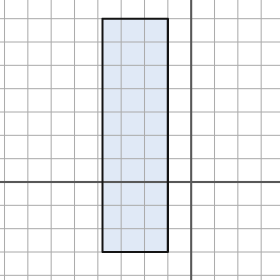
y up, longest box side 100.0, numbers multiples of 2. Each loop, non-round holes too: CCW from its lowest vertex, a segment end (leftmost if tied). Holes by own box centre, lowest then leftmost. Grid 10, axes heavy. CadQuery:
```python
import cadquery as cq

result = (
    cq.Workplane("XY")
    .moveTo(-38.0, -30.0)
    .lineTo(-10.0, -30.0)
    .lineTo(-10.0, 70.0)
    .lineTo(-38.0, 70.0)
    .close()
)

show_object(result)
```